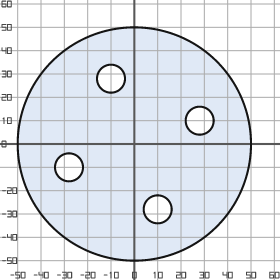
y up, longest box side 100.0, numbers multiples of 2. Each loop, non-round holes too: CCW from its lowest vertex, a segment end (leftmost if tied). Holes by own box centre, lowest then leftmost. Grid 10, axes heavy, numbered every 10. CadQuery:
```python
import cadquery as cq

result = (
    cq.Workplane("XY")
    .moveTo(0.0, 0.0)
    .circle(50.0)
    .moveTo(10.0, -28.0)
    .circle(6.0)
    .moveTo(-28.0, -10.0)
    .circle(6.0)
    .moveTo(28.0, 10.0)
    .circle(6.0)
    .moveTo(-10.0, 28.0)
    .circle(6.0)
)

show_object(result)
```